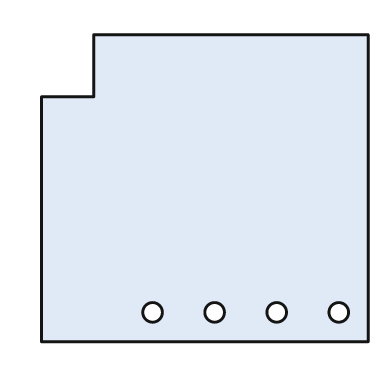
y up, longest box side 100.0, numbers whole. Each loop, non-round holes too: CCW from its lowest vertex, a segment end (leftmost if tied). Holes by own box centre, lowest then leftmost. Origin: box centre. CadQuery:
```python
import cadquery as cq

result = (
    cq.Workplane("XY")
    .moveTo(-50.0, -47.0)
    .lineTo(50.0, -47.0)
    .lineTo(50.0, 47.0)
    .lineTo(-34.0, 47.0)
    .lineTo(-34.0, 28.0)
    .lineTo(-50.0, 28.0)
    .close()
    .moveTo(-16.0, -38.0)
    .circle(3.0)
    .moveTo(3.0, -38.0)
    .circle(3.0)
    .moveTo(22.0, -38.0)
    .circle(3.0)
    .moveTo(41.0, -38.0)
    .circle(3.0)
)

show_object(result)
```